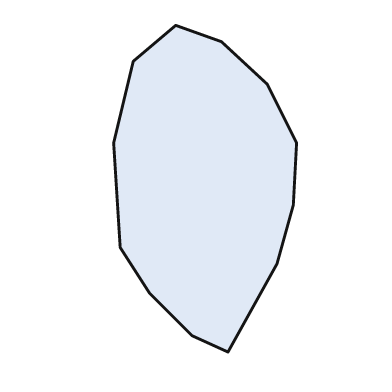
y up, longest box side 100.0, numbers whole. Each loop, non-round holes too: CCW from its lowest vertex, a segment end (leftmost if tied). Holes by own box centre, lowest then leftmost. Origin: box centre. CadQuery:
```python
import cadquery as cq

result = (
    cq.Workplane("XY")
    .moveTo(7.0, -50.0)
    .lineTo(22.0, -23.0)
    .lineTo(27.0, -5.0)
    .lineTo(28.0, 14.0)
    .lineTo(19.0, 32.0)
    .lineTo(5.0, 45.0)
    .lineTo(-9.0, 50.0)
    .lineTo(-22.0, 39.0)
    .lineTo(-28.0, 14.0)
    .lineTo(-26.0, -18.0)
    .lineTo(-17.0, -32.0)
    .lineTo(-4.0, -45.0)
    .close()
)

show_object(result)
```